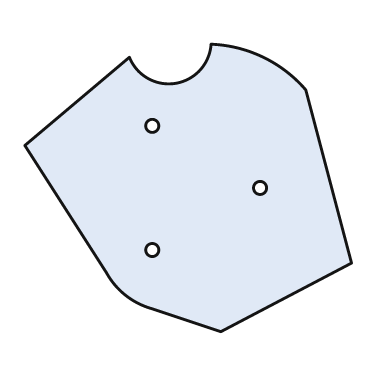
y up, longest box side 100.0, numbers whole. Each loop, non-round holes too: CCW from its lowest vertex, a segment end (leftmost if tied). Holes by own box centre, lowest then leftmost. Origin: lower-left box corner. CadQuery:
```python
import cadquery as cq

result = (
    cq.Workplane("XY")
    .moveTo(60.0, 0.0)
    .lineTo(100.0, 21.0)
    .lineTo(86.0, 74.0)
    .threePointArc((73.0, 84.0), (57.0, 88.0))
    .threePointArc((46.0, 76.0), (32.0, 84.0))
    .lineTo(0.0, 57.0)
    .lineTo(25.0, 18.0)
    .threePointArc((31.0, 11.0), (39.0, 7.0))
    .close()
    .moveTo(39.0, 25.0)
    .circle(2.0)
    .moveTo(72.0, 44.0)
    .circle(2.0)
    .moveTo(39.0, 63.0)
    .circle(2.0)
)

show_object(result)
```